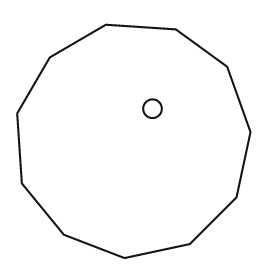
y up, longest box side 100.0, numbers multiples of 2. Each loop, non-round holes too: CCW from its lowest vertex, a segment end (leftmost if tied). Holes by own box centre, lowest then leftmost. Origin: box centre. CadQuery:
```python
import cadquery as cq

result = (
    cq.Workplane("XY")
    .moveTo(-4.0, -50.0)
    .lineTo(24.0, -44.0)
    .lineTo(44.0, -24.0)
    .lineTo(50.0, 4.0)
    .lineTo(40.0, 32.0)
    .lineTo(18.0, 48.0)
    .lineTo(-12.0, 50.0)
    .lineTo(-36.0, 36.0)
    .lineTo(-50.0, 12.0)
    .lineTo(-48.0, -18.0)
    .lineTo(-30.0, -40.0)
    .close()
    .moveTo(8.0, 14.0)
    .circle(4.0)
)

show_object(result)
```